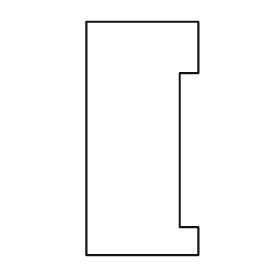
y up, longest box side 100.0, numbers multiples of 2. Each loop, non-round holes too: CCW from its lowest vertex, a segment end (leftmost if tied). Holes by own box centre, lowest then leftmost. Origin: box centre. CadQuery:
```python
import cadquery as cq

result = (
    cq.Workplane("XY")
    .moveTo(-24.0, -50.0)
    .lineTo(24.0, -50.0)
    .lineTo(24.0, -38.0)
    .lineTo(16.0, -38.0)
    .lineTo(16.0, 28.0)
    .lineTo(24.0, 28.0)
    .lineTo(24.0, 50.0)
    .lineTo(-24.0, 50.0)
    .close()
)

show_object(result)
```